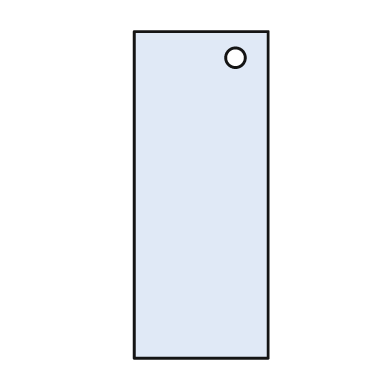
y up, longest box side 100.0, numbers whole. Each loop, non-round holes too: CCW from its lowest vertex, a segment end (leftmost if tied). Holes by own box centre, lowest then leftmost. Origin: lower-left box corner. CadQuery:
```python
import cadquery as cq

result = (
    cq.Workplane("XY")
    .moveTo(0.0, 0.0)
    .lineTo(41.0, 0.0)
    .lineTo(41.0, 100.0)
    .lineTo(0.0, 100.0)
    .close()
    .moveTo(31.0, 92.0)
    .circle(3.0)
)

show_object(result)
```